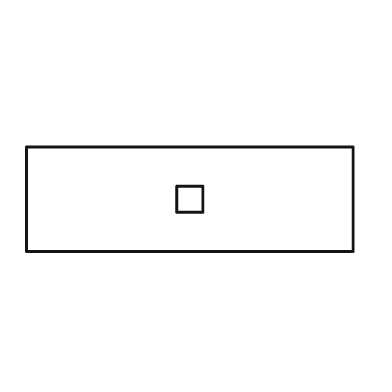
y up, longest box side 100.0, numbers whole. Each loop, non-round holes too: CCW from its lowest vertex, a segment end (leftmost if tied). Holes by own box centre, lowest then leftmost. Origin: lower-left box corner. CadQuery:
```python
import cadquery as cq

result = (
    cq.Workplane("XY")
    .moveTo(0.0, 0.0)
    .lineTo(100.0, 0.0)
    .lineTo(100.0, 32.0)
    .lineTo(0.0, 32.0)
    .close()
    .moveTo(46.0, 12.0)
    .lineTo(54.0, 12.0)
    .lineTo(54.0, 20.0)
    .lineTo(46.0, 20.0)
    .close()
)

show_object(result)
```